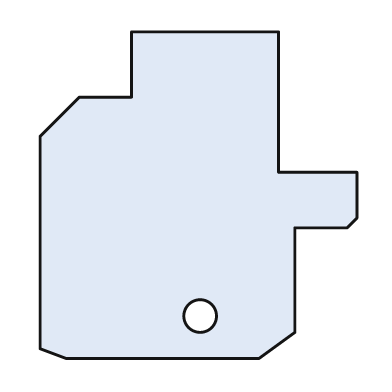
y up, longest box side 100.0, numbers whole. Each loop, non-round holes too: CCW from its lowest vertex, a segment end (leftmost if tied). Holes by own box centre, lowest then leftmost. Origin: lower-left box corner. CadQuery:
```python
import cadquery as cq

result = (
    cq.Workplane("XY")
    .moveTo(8.0, 0.0)
    .lineTo(67.0, 0.0)
    .lineTo(78.0, 8.0)
    .lineTo(78.0, 40.0)
    .lineTo(94.0, 40.0)
    .lineTo(97.0, 43.0)
    .lineTo(97.0, 57.0)
    .lineTo(73.0, 57.0)
    .lineTo(73.0, 100.0)
    .lineTo(28.0, 100.0)
    .lineTo(28.0, 80.0)
    .lineTo(12.0, 80.0)
    .lineTo(0.0, 68.0)
    .lineTo(0.0, 3.0)
    .close()
    .moveTo(49.0, 13.0)
    .circle(5.0)
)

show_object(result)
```